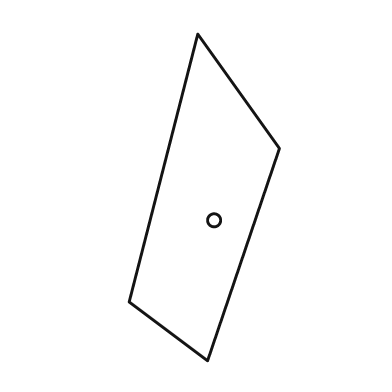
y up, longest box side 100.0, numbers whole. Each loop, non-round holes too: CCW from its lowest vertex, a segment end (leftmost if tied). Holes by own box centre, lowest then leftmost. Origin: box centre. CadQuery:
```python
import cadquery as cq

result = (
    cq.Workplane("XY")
    .moveTo(1.0, -50.0)
    .lineTo(23.0, 15.0)
    .lineTo(-2.0, 50.0)
    .lineTo(-23.0, -32.0)
    .close()
    .moveTo(3.0, -7.0)
    .circle(2.0)
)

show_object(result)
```